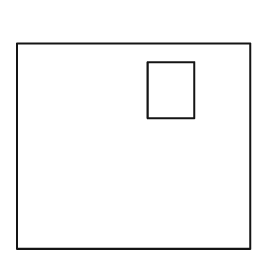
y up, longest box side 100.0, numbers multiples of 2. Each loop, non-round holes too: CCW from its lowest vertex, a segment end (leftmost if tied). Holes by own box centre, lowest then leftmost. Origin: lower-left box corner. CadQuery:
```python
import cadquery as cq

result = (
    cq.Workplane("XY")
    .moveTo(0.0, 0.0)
    .lineTo(100.0, 0.0)
    .lineTo(100.0, 88.0)
    .lineTo(0.0, 88.0)
    .close()
    .moveTo(56.0, 56.0)
    .lineTo(76.0, 56.0)
    .lineTo(76.0, 80.0)
    .lineTo(56.0, 80.0)
    .close()
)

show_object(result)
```